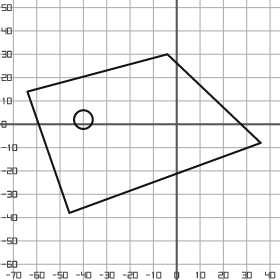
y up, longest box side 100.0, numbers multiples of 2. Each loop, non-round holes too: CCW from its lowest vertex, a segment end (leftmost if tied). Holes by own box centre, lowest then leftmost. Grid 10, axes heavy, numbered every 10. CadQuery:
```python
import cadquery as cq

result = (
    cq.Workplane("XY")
    .moveTo(-46.0, -38.0)
    .lineTo(36.0, -8.0)
    .lineTo(-4.0, 30.0)
    .lineTo(-64.0, 14.0)
    .close()
    .moveTo(-40.0, 2.0)
    .circle(4.0)
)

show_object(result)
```